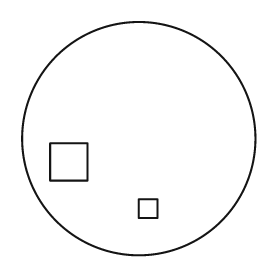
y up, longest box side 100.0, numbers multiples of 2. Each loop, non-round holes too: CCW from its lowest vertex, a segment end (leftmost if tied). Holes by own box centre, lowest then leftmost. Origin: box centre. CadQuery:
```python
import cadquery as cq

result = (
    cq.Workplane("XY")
    .moveTo(0.0, 0.0)
    .circle(50.0)
    .moveTo(0.0, -34.0)
    .lineTo(8.0, -34.0)
    .lineTo(8.0, -26.0)
    .lineTo(0.0, -26.0)
    .close()
    .moveTo(-38.0, -18.0)
    .lineTo(-22.0, -18.0)
    .lineTo(-22.0, -2.0)
    .lineTo(-38.0, -2.0)
    .close()
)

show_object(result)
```